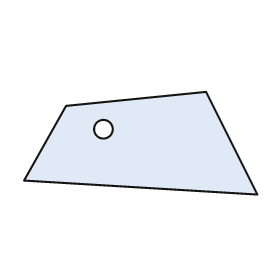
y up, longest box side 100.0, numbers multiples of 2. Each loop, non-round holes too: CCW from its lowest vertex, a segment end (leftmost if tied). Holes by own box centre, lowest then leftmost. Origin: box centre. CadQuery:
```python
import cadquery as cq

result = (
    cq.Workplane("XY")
    .moveTo(50.0, -22.0)
    .lineTo(28.0, 22.0)
    .lineTo(-32.0, 16.0)
    .lineTo(-50.0, -16.0)
    .close()
    .moveTo(-16.0, 6.0)
    .circle(4.0)
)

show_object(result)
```